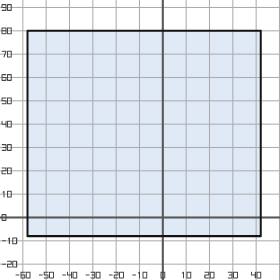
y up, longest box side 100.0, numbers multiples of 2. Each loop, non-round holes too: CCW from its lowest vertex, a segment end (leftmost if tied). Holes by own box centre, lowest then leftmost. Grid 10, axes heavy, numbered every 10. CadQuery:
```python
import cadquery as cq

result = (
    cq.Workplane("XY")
    .moveTo(-58.0, -8.0)
    .lineTo(42.0, -8.0)
    .lineTo(42.0, 80.0)
    .lineTo(-58.0, 80.0)
    .close()
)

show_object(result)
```